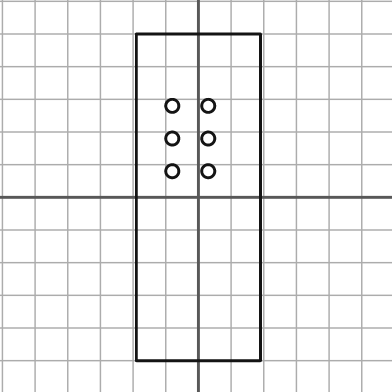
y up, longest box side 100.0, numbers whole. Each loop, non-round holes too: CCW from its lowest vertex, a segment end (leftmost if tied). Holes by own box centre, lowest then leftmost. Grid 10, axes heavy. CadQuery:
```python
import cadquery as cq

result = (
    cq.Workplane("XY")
    .moveTo(-19.0, -50.0)
    .lineTo(19.0, -50.0)
    .lineTo(19.0, 50.0)
    .lineTo(-19.0, 50.0)
    .close()
    .moveTo(-8.0, 8.0)
    .circle(2.0)
    .moveTo(3.0, 8.0)
    .circle(2.0)
    .moveTo(-8.0, 18.0)
    .circle(2.0)
    .moveTo(3.0, 18.0)
    .circle(2.0)
    .moveTo(-8.0, 28.0)
    .circle(2.0)
    .moveTo(3.0, 28.0)
    .circle(2.0)
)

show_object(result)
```